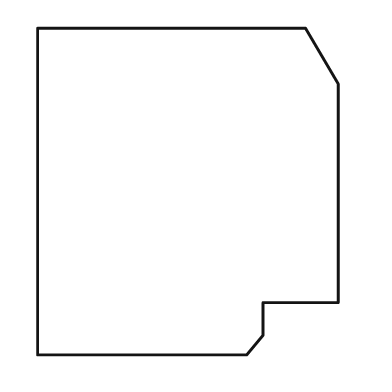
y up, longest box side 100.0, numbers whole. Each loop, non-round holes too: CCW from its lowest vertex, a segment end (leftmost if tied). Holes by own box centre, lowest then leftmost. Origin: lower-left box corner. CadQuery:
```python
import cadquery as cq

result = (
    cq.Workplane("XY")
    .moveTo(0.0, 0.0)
    .lineTo(64.0, 0.0)
    .lineTo(69.0, 6.0)
    .lineTo(69.0, 16.0)
    .lineTo(92.0, 16.0)
    .lineTo(92.0, 83.0)
    .lineTo(82.0, 100.0)
    .lineTo(0.0, 100.0)
    .close()
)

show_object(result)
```